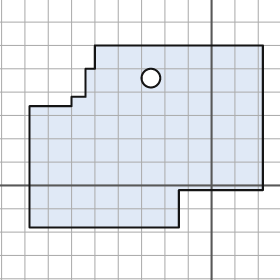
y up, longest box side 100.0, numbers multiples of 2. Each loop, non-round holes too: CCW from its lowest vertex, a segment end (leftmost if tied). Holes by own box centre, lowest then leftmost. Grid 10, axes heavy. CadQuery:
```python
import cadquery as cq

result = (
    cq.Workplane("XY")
    .moveTo(-78.0, -18.0)
    .lineTo(-14.0, -18.0)
    .lineTo(-14.0, -2.0)
    .lineTo(22.0, -2.0)
    .lineTo(22.0, 60.0)
    .lineTo(-50.0, 60.0)
    .lineTo(-50.0, 50.0)
    .lineTo(-54.0, 50.0)
    .lineTo(-54.0, 38.0)
    .lineTo(-60.0, 38.0)
    .lineTo(-60.0, 34.0)
    .lineTo(-78.0, 34.0)
    .close()
    .moveTo(-26.0, 46.0)
    .circle(4.0)
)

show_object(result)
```